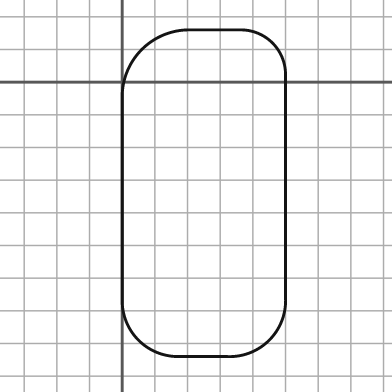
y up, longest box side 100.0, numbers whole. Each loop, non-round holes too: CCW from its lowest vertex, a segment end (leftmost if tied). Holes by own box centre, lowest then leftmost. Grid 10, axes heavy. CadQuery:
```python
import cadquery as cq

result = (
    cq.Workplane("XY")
    .moveTo(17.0, -84.0)
    .lineTo(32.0, -84.0)
    .threePointArc((45.0, -79.0), (50.0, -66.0))
    .lineTo(50.0, 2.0)
    .threePointArc((46.0, 12.0), (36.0, 16.0))
    .lineTo(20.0, 16.0)
    .threePointArc((6.0, 10.0), (0.0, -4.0))
    .lineTo(0.0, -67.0)
    .threePointArc((5.0, -79.0), (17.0, -84.0))
    .close()
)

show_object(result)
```